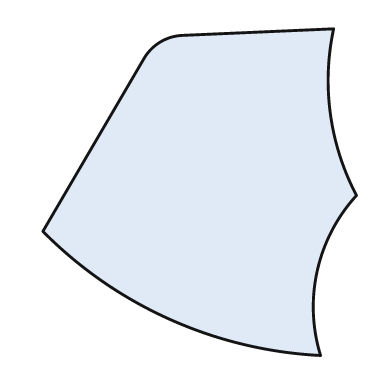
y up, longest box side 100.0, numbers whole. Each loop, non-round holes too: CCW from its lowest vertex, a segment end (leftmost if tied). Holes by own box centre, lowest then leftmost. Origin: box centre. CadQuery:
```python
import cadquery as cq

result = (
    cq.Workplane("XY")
    .moveTo(37.0, -50.0)
    .threePointArc((36.0, -24.0), (48.0, -1.0))
    .threePointArc((40.0, 24.0), (41.0, 50.0))
    .lineTo(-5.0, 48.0)
    .threePointArc((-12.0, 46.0), (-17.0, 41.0))
    .lineTo(-48.0, -12.0)
    .threePointArc((-9.0, -39.0), (37.0, -50.0))
    .close()
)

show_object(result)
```